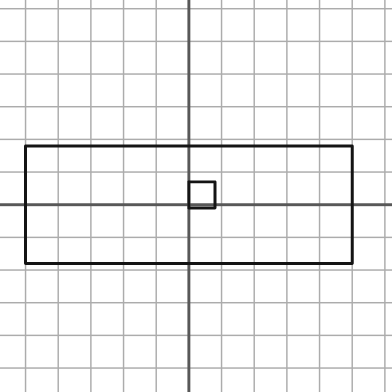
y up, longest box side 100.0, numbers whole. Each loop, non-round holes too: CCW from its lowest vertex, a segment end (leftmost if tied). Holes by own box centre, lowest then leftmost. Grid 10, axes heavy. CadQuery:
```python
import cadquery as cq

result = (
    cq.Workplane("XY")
    .moveTo(-50.0, -18.0)
    .lineTo(50.0, -18.0)
    .lineTo(50.0, 18.0)
    .lineTo(-50.0, 18.0)
    .close()
    .moveTo(0.0, -1.0)
    .lineTo(8.0, -1.0)
    .lineTo(8.0, 7.0)
    .lineTo(0.0, 7.0)
    .close()
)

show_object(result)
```